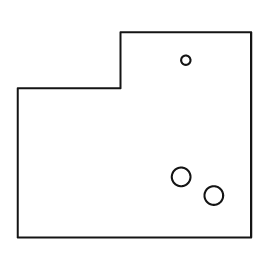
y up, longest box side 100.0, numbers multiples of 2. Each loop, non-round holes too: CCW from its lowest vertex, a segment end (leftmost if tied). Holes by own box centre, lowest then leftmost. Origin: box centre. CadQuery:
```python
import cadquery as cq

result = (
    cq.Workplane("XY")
    .moveTo(-50.0, -44.0)
    .lineTo(50.0, -44.0)
    .lineTo(50.0, 44.0)
    .lineTo(-6.0, 44.0)
    .lineTo(-6.0, 20.0)
    .lineTo(-50.0, 20.0)
    .close()
    .moveTo(34.0, -26.0)
    .circle(4.0)
    .moveTo(20.0, -18.0)
    .circle(4.0)
    .moveTo(22.0, 32.0)
    .circle(2.0)
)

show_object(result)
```